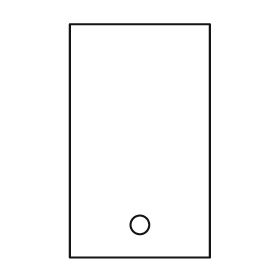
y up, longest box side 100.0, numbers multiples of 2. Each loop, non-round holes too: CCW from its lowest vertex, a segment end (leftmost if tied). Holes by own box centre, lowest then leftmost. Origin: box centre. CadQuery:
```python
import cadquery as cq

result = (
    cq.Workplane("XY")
    .moveTo(-30.0, -50.0)
    .lineTo(30.0, -50.0)
    .lineTo(30.0, 50.0)
    .lineTo(-30.0, 50.0)
    .close()
    .moveTo(0.0, -36.0)
    .circle(4.0)
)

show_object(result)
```